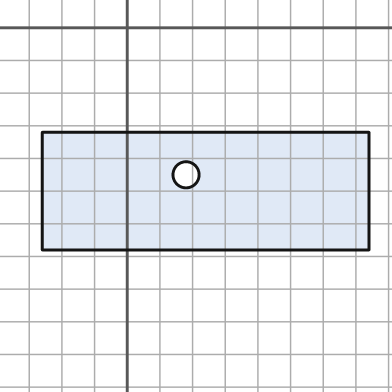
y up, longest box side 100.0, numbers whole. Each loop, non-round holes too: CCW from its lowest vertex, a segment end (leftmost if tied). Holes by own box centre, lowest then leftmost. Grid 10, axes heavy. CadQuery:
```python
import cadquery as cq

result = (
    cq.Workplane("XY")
    .moveTo(-26.0, -68.0)
    .lineTo(74.0, -68.0)
    .lineTo(74.0, -32.0)
    .lineTo(-26.0, -32.0)
    .close()
    .moveTo(18.0, -45.0)
    .circle(4.0)
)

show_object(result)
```